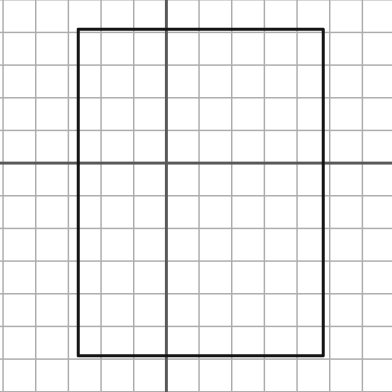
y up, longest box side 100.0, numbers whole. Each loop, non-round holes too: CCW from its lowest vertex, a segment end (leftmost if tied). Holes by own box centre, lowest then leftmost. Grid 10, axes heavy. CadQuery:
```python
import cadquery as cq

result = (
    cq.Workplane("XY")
    .moveTo(-27.0, -59.0)
    .lineTo(48.0, -59.0)
    .lineTo(48.0, 41.0)
    .lineTo(-27.0, 41.0)
    .close()
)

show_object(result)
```